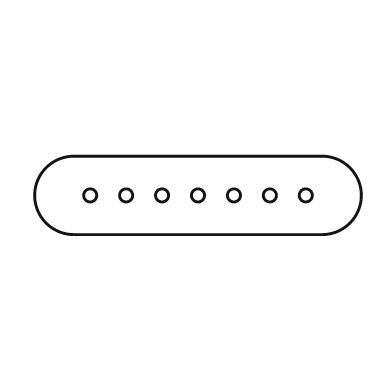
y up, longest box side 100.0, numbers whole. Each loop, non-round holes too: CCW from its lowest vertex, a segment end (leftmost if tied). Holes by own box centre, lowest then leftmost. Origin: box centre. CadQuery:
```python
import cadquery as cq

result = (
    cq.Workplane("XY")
    .moveTo(-38.0, -12.0)
    .lineTo(38.0, -12.0)
    .threePointArc((50.0, 0.0), (38.0, 12.0))
    .lineTo(-38.0, 12.0)
    .threePointArc((-50.0, 0.0), (-38.0, -12.0))
    .close()
    .moveTo(-33.0, 0.0)
    .circle(2.0)
    .moveTo(-22.0, 0.0)
    .circle(2.0)
    .moveTo(-11.0, 0.0)
    .circle(2.0)
    .moveTo(0.0, 0.0)
    .circle(2.0)
    .moveTo(11.0, 0.0)
    .circle(2.0)
    .moveTo(22.0, 0.0)
    .circle(2.0)
    .moveTo(33.0, 0.0)
    .circle(2.0)
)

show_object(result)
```